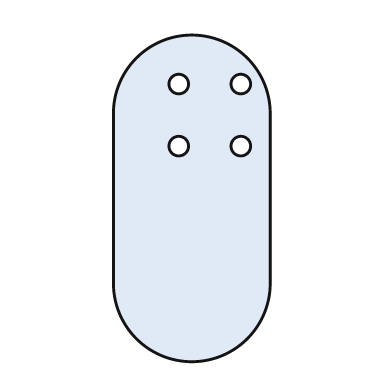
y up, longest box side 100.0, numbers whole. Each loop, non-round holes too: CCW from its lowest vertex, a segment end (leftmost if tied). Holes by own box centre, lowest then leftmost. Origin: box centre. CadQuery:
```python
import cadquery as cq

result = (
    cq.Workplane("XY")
    .moveTo(-24.0, -26.0)
    .threePointArc((0.0, -50.0), (24.0, -26.0))
    .lineTo(24.0, 26.0)
    .threePointArc((0.0, 50.0), (-24.0, 26.0))
    .close()
    .moveTo(-4.0, 16.0)
    .circle(3.0)
    .moveTo(15.0, 16.0)
    .circle(3.0)
    .moveTo(-4.0, 35.0)
    .circle(3.0)
    .moveTo(15.0, 35.0)
    .circle(3.0)
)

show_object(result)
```